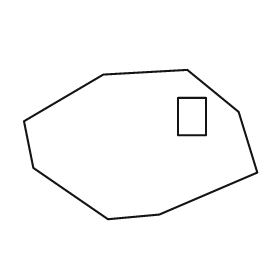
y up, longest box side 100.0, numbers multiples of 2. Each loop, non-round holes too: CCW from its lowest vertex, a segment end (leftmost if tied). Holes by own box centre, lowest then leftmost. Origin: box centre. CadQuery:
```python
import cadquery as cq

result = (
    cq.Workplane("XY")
    .moveTo(-14.0, -32.0)
    .lineTo(8.0, -30.0)
    .lineTo(50.0, -12.0)
    .lineTo(42.0, 14.0)
    .lineTo(20.0, 32.0)
    .lineTo(-16.0, 30.0)
    .lineTo(-50.0, 10.0)
    .lineTo(-46.0, -10.0)
    .close()
    .moveTo(16.0, 4.0)
    .lineTo(28.0, 4.0)
    .lineTo(28.0, 20.0)
    .lineTo(16.0, 20.0)
    .close()
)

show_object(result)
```